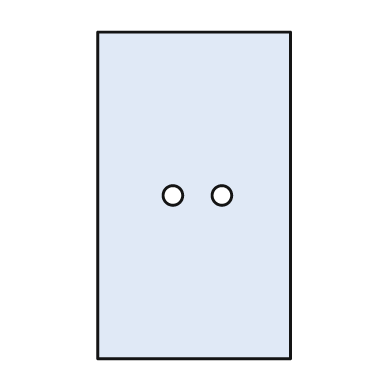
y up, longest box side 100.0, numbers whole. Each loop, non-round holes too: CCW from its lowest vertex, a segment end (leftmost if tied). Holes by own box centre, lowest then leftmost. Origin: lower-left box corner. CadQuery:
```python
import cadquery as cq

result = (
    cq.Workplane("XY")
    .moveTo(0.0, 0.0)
    .lineTo(59.0, 0.0)
    .lineTo(59.0, 100.0)
    .lineTo(0.0, 100.0)
    .close()
    .moveTo(23.0, 50.0)
    .circle(3.0)
    .moveTo(38.0, 50.0)
    .circle(3.0)
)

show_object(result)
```